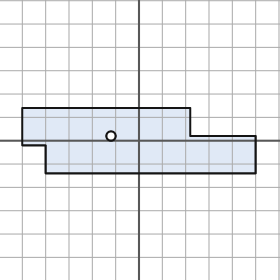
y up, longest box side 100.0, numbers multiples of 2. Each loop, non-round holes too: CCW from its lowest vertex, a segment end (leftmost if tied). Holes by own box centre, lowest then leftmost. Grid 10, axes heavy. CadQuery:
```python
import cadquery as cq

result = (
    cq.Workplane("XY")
    .moveTo(-40.0, -14.0)
    .lineTo(50.0, -14.0)
    .lineTo(50.0, 2.0)
    .lineTo(22.0, 2.0)
    .lineTo(22.0, 14.0)
    .lineTo(-50.0, 14.0)
    .lineTo(-50.0, -2.0)
    .lineTo(-40.0, -2.0)
    .close()
    .moveTo(-12.0, 2.0)
    .circle(2.0)
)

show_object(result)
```